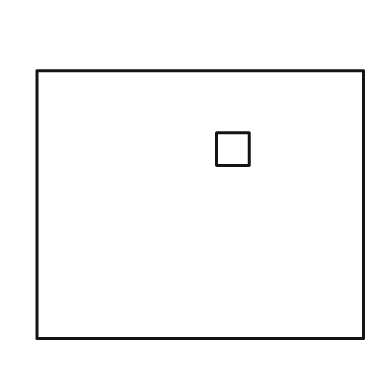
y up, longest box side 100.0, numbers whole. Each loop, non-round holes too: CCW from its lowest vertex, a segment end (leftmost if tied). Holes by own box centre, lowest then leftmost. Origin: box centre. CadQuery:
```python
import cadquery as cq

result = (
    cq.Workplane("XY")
    .moveTo(-50.0, -41.0)
    .lineTo(50.0, -41.0)
    .lineTo(50.0, 41.0)
    .lineTo(-50.0, 41.0)
    .close()
    .moveTo(5.0, 12.0)
    .lineTo(15.0, 12.0)
    .lineTo(15.0, 22.0)
    .lineTo(5.0, 22.0)
    .close()
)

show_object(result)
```